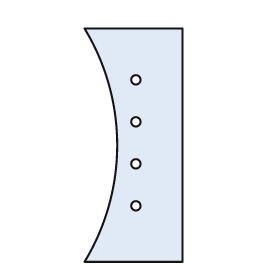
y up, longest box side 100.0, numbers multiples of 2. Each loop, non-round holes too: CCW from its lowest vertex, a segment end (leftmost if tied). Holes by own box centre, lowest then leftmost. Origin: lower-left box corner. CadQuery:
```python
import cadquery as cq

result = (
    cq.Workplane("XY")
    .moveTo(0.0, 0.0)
    .lineTo(42.0, 0.0)
    .lineTo(42.0, 100.0)
    .lineTo(0.0, 100.0)
    .threePointArc((14.0, 50.0), (0.0, 0.0))
    .close()
    .moveTo(22.0, 24.0)
    .circle(2.0)
    .moveTo(22.0, 42.0)
    .circle(2.0)
    .moveTo(22.0, 60.0)
    .circle(2.0)
    .moveTo(22.0, 78.0)
    .circle(2.0)
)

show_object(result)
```